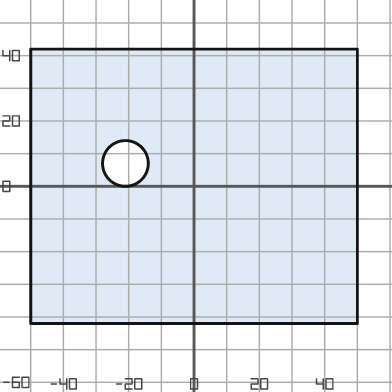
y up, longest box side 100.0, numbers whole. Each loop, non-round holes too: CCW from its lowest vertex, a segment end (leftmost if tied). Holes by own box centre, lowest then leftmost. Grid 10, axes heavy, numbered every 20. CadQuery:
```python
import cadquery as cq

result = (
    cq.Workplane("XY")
    .moveTo(-50.0, -42.0)
    .lineTo(50.0, -42.0)
    .lineTo(50.0, 42.0)
    .lineTo(-50.0, 42.0)
    .close()
    .moveTo(-21.0, 7.0)
    .circle(7.0)
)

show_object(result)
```